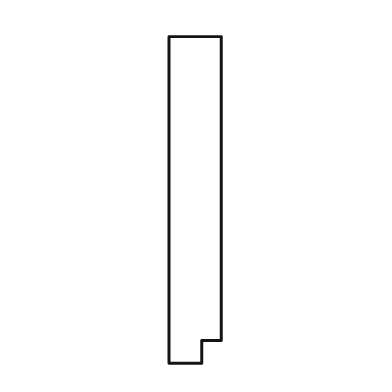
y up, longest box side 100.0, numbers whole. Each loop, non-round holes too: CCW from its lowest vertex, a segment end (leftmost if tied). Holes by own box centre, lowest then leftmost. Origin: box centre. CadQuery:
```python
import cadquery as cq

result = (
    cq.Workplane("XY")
    .moveTo(-8.0, -50.0)
    .lineTo(2.0, -50.0)
    .lineTo(2.0, -43.0)
    .lineTo(8.0, -43.0)
    .lineTo(8.0, 50.0)
    .lineTo(-8.0, 50.0)
    .close()
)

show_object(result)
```